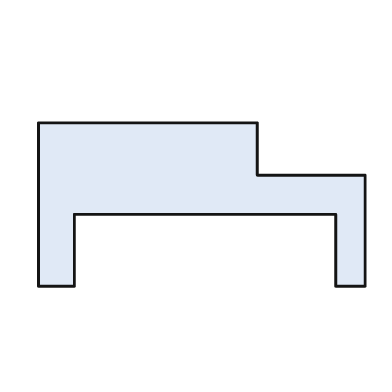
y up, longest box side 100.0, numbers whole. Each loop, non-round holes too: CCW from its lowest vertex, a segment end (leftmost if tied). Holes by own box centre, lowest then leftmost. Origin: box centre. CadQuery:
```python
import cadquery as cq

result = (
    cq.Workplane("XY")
    .moveTo(-50.0, -25.0)
    .lineTo(-39.0, -25.0)
    .lineTo(-39.0, -3.0)
    .lineTo(41.0, -3.0)
    .lineTo(41.0, -25.0)
    .lineTo(50.0, -25.0)
    .lineTo(50.0, 9.0)
    .lineTo(17.0, 9.0)
    .lineTo(17.0, 25.0)
    .lineTo(-50.0, 25.0)
    .close()
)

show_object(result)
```